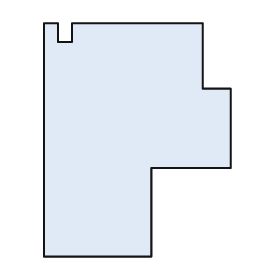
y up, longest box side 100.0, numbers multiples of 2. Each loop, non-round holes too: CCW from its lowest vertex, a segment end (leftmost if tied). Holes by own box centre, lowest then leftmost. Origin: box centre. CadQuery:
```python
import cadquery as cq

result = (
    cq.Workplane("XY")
    .moveTo(-40.0, -50.0)
    .lineTo(6.0, -50.0)
    .lineTo(6.0, -12.0)
    .lineTo(40.0, -12.0)
    .lineTo(40.0, 22.0)
    .lineTo(28.0, 22.0)
    .lineTo(28.0, 50.0)
    .lineTo(-28.0, 50.0)
    .lineTo(-28.0, 42.0)
    .lineTo(-34.0, 42.0)
    .lineTo(-34.0, 50.0)
    .lineTo(-40.0, 50.0)
    .close()
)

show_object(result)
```